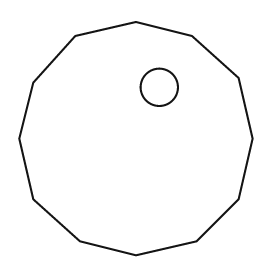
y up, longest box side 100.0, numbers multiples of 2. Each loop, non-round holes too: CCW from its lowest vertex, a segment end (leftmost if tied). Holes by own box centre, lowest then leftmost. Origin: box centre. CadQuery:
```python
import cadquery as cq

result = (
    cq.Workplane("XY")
    .moveTo(0.0, -50.0)
    .lineTo(26.0, -44.0)
    .lineTo(44.0, -26.0)
    .lineTo(50.0, 0.0)
    .lineTo(44.0, 26.0)
    .lineTo(24.0, 44.0)
    .lineTo(0.0, 50.0)
    .lineTo(-26.0, 44.0)
    .lineTo(-44.0, 24.0)
    .lineTo(-50.0, 0.0)
    .lineTo(-44.0, -26.0)
    .lineTo(-24.0, -44.0)
    .close()
    .moveTo(10.0, 22.0)
    .circle(8.0)
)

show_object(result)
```